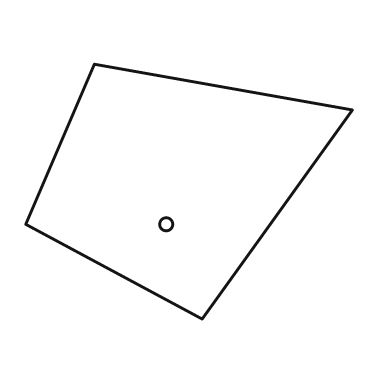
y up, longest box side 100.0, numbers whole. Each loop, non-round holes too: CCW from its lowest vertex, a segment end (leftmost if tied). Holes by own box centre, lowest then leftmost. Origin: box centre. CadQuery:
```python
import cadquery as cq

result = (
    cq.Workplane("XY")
    .moveTo(4.0, -39.0)
    .lineTo(50.0, 25.0)
    .lineTo(-29.0, 39.0)
    .lineTo(-50.0, -10.0)
    .close()
    .moveTo(-7.0, -10.0)
    .circle(2.0)
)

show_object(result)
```